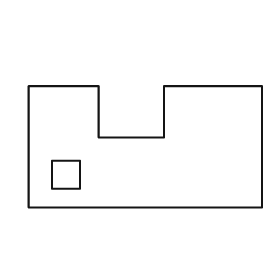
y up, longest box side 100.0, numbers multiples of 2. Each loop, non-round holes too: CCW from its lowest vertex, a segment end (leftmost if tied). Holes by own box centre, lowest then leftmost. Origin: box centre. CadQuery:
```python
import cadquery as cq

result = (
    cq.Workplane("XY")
    .moveTo(-50.0, -26.0)
    .lineTo(50.0, -26.0)
    .lineTo(50.0, 26.0)
    .lineTo(8.0, 26.0)
    .lineTo(8.0, 4.0)
    .lineTo(-20.0, 4.0)
    .lineTo(-20.0, 26.0)
    .lineTo(-50.0, 26.0)
    .close()
    .moveTo(-40.0, -18.0)
    .lineTo(-28.0, -18.0)
    .lineTo(-28.0, -6.0)
    .lineTo(-40.0, -6.0)
    .close()
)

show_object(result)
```